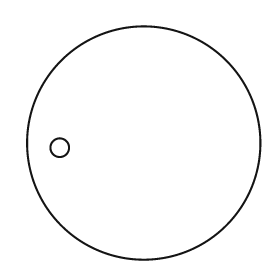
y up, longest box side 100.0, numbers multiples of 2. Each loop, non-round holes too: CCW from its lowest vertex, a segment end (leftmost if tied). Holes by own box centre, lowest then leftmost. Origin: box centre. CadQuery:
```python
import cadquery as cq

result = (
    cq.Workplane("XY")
    .moveTo(0.0, 0.0)
    .circle(50.0)
    .moveTo(-36.0, -2.0)
    .circle(4.0)
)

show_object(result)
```